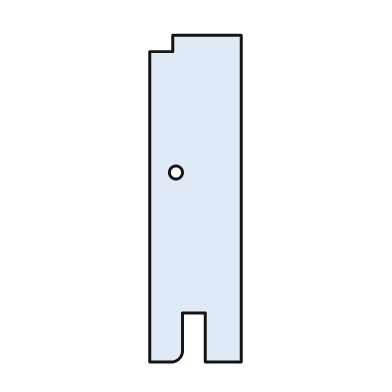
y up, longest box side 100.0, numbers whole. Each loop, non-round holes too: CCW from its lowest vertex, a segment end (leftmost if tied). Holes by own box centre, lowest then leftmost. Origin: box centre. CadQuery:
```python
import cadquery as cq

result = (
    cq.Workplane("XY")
    .moveTo(-14.0, -50.0)
    .lineTo(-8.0, -50.0)
    .threePointArc((-5.0, -49.0), (-4.0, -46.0))
    .lineTo(-4.0, -35.0)
    .lineTo(3.0, -35.0)
    .lineTo(3.0, -50.0)
    .lineTo(14.0, -50.0)
    .lineTo(14.0, 50.0)
    .lineTo(-7.0, 50.0)
    .lineTo(-7.0, 45.0)
    .lineTo(-14.0, 45.0)
    .close()
    .moveTo(-6.0, 8.0)
    .circle(2.0)
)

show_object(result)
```